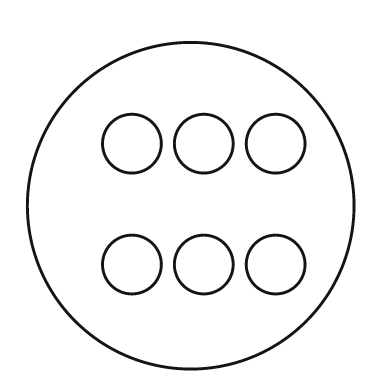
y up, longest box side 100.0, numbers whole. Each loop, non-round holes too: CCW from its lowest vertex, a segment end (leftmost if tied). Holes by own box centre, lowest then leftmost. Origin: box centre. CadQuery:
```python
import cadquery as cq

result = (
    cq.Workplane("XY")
    .moveTo(0.0, 0.0)
    .circle(50.0)
    .moveTo(-18.0, -18.0)
    .circle(9.0)
    .moveTo(4.0, -18.0)
    .circle(9.0)
    .moveTo(26.0, -18.0)
    .circle(9.0)
    .moveTo(-18.0, 19.0)
    .circle(9.0)
    .moveTo(4.0, 19.0)
    .circle(9.0)
    .moveTo(26.0, 19.0)
    .circle(9.0)
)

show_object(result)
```